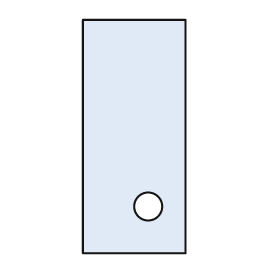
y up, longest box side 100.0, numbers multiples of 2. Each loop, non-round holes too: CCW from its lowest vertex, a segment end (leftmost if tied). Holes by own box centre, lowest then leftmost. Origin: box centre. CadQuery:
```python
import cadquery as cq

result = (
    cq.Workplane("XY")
    .moveTo(-22.0, -50.0)
    .lineTo(22.0, -50.0)
    .lineTo(22.0, 50.0)
    .lineTo(-22.0, 50.0)
    .close()
    .moveTo(6.0, -30.0)
    .circle(6.0)
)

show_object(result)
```